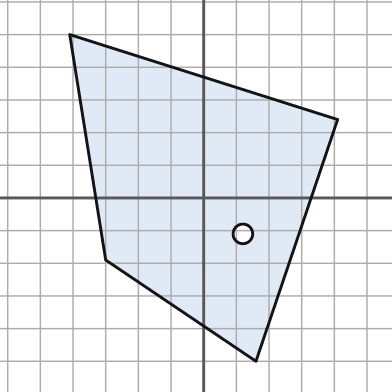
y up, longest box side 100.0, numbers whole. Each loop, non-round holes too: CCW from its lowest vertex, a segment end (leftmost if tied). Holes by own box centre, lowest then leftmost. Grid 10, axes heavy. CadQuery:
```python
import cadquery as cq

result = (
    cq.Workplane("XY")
    .moveTo(16.0, -50.0)
    .lineTo(41.0, 24.0)
    .lineTo(-41.0, 50.0)
    .lineTo(-30.0, -19.0)
    .close()
    .moveTo(12.0, -11.0)
    .circle(3.0)
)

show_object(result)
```